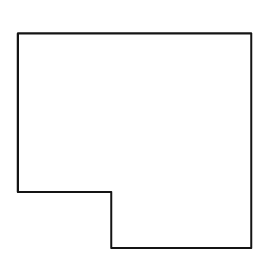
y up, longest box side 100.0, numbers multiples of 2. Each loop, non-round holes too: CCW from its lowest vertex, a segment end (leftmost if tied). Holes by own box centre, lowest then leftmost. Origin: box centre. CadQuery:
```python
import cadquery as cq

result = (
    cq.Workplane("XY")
    .moveTo(-10.0, -46.0)
    .lineTo(50.0, -46.0)
    .lineTo(50.0, 46.0)
    .lineTo(-50.0, 46.0)
    .lineTo(-50.0, -22.0)
    .lineTo(-10.0, -22.0)
    .close()
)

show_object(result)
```